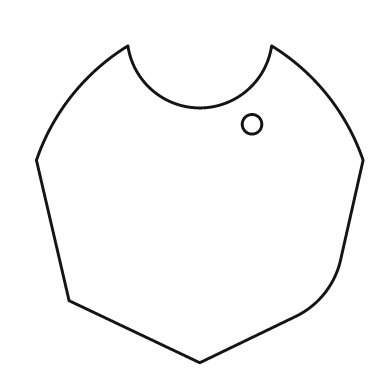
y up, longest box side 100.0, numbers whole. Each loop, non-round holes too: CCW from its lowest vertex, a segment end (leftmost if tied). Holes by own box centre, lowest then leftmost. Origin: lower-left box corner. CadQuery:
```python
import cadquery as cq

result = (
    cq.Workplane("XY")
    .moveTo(50.0, 0.0)
    .lineTo(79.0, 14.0)
    .threePointArc((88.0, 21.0), (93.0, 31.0))
    .lineTo(100.0, 62.0)
    .threePointArc((89.0, 82.0), (72.0, 97.0))
    .threePointArc((50.0, 78.0), (28.0, 97.0))
    .threePointArc((11.0, 82.0), (0.0, 62.0))
    .lineTo(10.0, 19.0)
    .close()
    .moveTo(66.0, 73.0)
    .circle(3.0)
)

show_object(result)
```